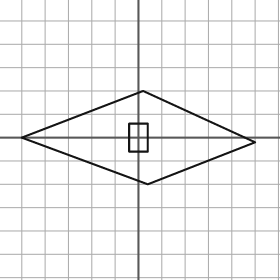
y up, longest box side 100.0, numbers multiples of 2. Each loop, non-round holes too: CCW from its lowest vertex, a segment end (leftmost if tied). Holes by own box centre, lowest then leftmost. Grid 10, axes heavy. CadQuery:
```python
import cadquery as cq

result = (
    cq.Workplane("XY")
    .moveTo(4.0, -20.0)
    .lineTo(50.0, -2.0)
    .lineTo(2.0, 20.0)
    .lineTo(-50.0, 0.0)
    .close()
    .moveTo(-4.0, -6.0)
    .lineTo(4.0, -6.0)
    .lineTo(4.0, 6.0)
    .lineTo(-4.0, 6.0)
    .close()
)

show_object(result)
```